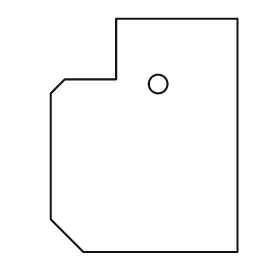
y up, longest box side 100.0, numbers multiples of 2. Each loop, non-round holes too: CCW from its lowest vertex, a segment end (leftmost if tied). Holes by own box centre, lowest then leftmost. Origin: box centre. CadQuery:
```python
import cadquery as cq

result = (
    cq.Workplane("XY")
    .moveTo(-26.0, -50.0)
    .lineTo(40.0, -50.0)
    .lineTo(40.0, 50.0)
    .lineTo(-12.0, 50.0)
    .lineTo(-12.0, 24.0)
    .lineTo(-34.0, 24.0)
    .lineTo(-40.0, 18.0)
    .lineTo(-40.0, -36.0)
    .close()
    .moveTo(6.0, 22.0)
    .circle(4.0)
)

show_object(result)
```